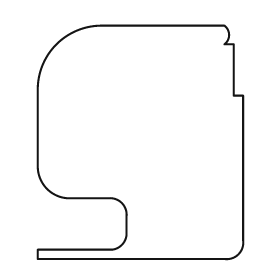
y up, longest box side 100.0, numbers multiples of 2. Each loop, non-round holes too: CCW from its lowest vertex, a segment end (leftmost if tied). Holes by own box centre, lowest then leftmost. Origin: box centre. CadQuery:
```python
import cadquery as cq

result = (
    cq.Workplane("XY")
    .moveTo(-44.0, -50.0)
    .lineTo(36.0, -50.0)
    .threePointArc((42.0, -48.0), (44.0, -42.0))
    .lineTo(44.0, 20.0)
    .lineTo(40.0, 20.0)
    .lineTo(40.0, 42.0)
    .lineTo(36.0, 42.0)
    .threePointArc((38.0, 46.0), (36.0, 50.0))
    .lineTo(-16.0, 50.0)
    .threePointArc((-36.0, 42.0), (-44.0, 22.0))
    .lineTo(-44.0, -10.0)
    .threePointArc((-40.0, -20.0), (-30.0, -24.0))
    .lineTo(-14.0, -24.0)
    .threePointArc((-8.0, -26.0), (-6.0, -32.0))
    .lineTo(-6.0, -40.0)
    .threePointArc((-8.0, -44.0), (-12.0, -46.0))
    .lineTo(-44.0, -46.0)
    .close()
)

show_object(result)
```